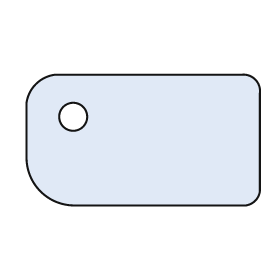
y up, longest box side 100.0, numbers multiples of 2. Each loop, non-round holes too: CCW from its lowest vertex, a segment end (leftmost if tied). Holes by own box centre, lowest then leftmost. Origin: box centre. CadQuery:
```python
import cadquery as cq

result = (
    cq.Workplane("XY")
    .moveTo(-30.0, -28.0)
    .lineTo(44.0, -28.0)
    .threePointArc((48.0, -26.0), (50.0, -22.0))
    .lineTo(50.0, 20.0)
    .threePointArc((48.0, 26.0), (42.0, 28.0))
    .lineTo(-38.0, 28.0)
    .threePointArc((-46.0, 24.0), (-50.0, 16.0))
    .lineTo(-50.0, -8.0)
    .threePointArc((-44.0, -22.0), (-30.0, -28.0))
    .close()
    .moveTo(-30.0, 10.0)
    .circle(6.0)
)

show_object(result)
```